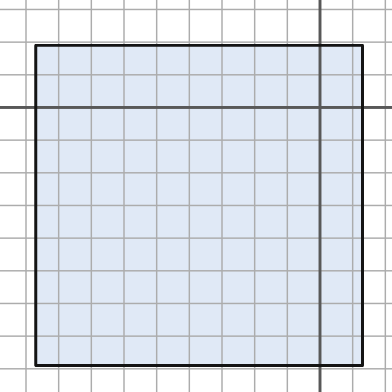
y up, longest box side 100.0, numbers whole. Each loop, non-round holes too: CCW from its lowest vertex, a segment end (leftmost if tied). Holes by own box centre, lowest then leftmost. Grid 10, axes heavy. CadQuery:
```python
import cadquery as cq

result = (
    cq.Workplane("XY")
    .moveTo(-87.0, -79.0)
    .lineTo(13.0, -79.0)
    .lineTo(13.0, 19.0)
    .lineTo(-87.0, 19.0)
    .close()
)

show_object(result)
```